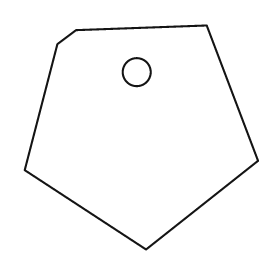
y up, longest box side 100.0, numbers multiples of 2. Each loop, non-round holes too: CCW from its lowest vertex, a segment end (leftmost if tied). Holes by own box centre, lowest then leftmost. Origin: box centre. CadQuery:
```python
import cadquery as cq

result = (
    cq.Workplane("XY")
    .moveTo(2.0, -48.0)
    .lineTo(50.0, -10.0)
    .lineTo(28.0, 48.0)
    .lineTo(-28.0, 46.0)
    .lineTo(-36.0, 40.0)
    .lineTo(-50.0, -14.0)
    .close()
    .moveTo(-2.0, 28.0)
    .circle(6.0)
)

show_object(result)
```